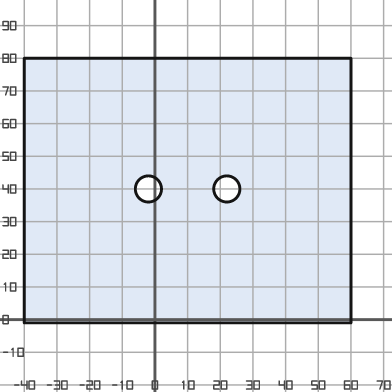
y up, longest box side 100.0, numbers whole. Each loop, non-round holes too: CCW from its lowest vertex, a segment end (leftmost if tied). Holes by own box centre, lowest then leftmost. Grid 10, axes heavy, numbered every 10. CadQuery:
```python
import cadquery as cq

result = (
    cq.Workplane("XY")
    .moveTo(-40.0, -1.0)
    .lineTo(60.0, -1.0)
    .lineTo(60.0, 80.0)
    .lineTo(-40.0, 80.0)
    .close()
    .moveTo(-2.0, 40.0)
    .circle(4.0)
    .moveTo(22.0, 40.0)
    .circle(4.0)
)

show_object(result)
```